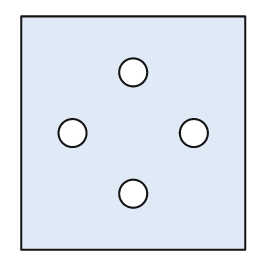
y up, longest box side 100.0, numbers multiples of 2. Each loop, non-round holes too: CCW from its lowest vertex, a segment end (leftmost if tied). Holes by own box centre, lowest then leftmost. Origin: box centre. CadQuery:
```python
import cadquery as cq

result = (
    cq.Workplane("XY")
    .moveTo(-48.0, -50.0)
    .lineTo(48.0, -50.0)
    .lineTo(48.0, 50.0)
    .lineTo(-48.0, 50.0)
    .close()
    .moveTo(0.0, -26.0)
    .circle(6.0)
    .moveTo(-26.0, 0.0)
    .circle(6.0)
    .moveTo(26.0, 0.0)
    .circle(6.0)
    .moveTo(0.0, 26.0)
    .circle(6.0)
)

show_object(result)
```